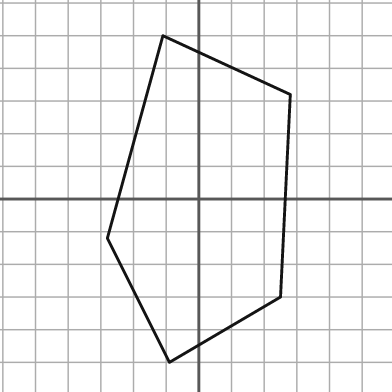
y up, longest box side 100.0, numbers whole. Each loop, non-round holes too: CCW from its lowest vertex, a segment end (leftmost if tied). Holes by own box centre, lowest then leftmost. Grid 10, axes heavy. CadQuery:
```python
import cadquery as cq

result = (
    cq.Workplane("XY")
    .moveTo(-9.0, -50.0)
    .lineTo(25.0, -30.0)
    .lineTo(28.0, 32.0)
    .lineTo(-11.0, 50.0)
    .lineTo(-28.0, -12.0)
    .close()
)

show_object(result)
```